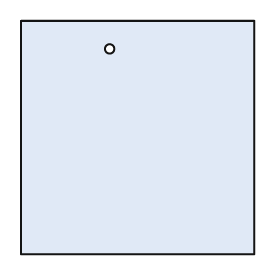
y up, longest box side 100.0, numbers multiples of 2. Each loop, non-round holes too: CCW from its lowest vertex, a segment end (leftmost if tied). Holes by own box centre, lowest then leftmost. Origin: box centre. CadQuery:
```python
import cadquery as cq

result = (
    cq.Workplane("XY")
    .moveTo(-50.0, -50.0)
    .lineTo(50.0, -50.0)
    .lineTo(50.0, 50.0)
    .lineTo(-50.0, 50.0)
    .close()
    .moveTo(-12.0, 38.0)
    .circle(2.0)
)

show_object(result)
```